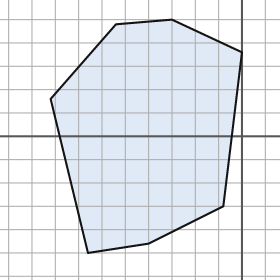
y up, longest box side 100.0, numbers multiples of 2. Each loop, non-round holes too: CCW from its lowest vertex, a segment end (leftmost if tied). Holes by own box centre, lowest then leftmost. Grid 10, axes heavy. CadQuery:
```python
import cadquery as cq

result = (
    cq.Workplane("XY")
    .moveTo(-66.0, -50.0)
    .lineTo(-40.0, -46.0)
    .lineTo(-8.0, -30.0)
    .lineTo(0.0, 36.0)
    .lineTo(-30.0, 50.0)
    .lineTo(-54.0, 48.0)
    .lineTo(-82.0, 16.0)
    .close()
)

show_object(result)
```